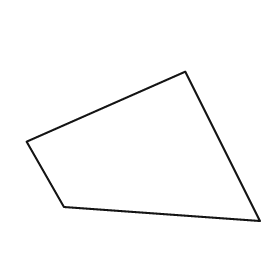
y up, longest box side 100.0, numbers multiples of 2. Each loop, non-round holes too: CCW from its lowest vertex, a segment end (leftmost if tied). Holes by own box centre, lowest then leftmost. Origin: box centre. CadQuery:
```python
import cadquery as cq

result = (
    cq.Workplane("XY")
    .moveTo(50.0, -32.0)
    .lineTo(18.0, 32.0)
    .lineTo(-50.0, 2.0)
    .lineTo(-34.0, -26.0)
    .close()
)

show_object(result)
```